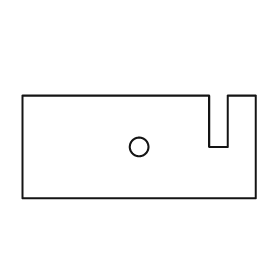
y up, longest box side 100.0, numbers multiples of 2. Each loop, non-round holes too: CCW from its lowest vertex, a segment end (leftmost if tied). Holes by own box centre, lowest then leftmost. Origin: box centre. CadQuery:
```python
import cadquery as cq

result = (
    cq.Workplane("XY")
    .moveTo(-50.0, -22.0)
    .lineTo(50.0, -22.0)
    .lineTo(50.0, 22.0)
    .lineTo(38.0, 22.0)
    .lineTo(38.0, 0.0)
    .lineTo(30.0, 0.0)
    .lineTo(30.0, 22.0)
    .lineTo(-50.0, 22.0)
    .close()
    .moveTo(0.0, 0.0)
    .circle(4.0)
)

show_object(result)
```